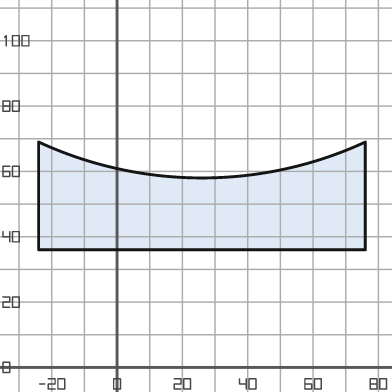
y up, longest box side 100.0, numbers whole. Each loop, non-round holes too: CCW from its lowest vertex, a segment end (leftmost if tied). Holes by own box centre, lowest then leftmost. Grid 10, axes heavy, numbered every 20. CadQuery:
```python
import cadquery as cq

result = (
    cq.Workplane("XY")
    .moveTo(-24.0, 36.0)
    .lineTo(76.0, 36.0)
    .lineTo(76.0, 69.0)
    .threePointArc((26.0, 58.0), (-24.0, 69.0))
    .close()
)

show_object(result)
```